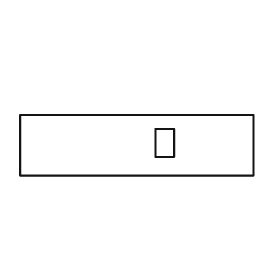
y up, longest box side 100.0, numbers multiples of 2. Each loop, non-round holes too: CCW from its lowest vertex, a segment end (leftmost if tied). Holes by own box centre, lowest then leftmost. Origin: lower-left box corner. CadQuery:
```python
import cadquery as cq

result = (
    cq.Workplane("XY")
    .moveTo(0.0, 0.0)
    .lineTo(100.0, 0.0)
    .lineTo(100.0, 26.0)
    .lineTo(0.0, 26.0)
    .close()
    .moveTo(58.0, 8.0)
    .lineTo(66.0, 8.0)
    .lineTo(66.0, 20.0)
    .lineTo(58.0, 20.0)
    .close()
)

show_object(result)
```